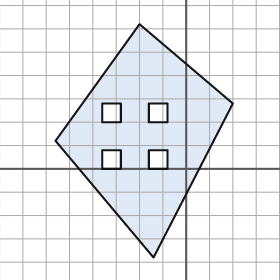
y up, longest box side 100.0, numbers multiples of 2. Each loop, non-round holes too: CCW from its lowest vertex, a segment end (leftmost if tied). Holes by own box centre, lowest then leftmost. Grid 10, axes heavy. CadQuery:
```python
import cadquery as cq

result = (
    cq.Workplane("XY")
    .moveTo(-14.0, -38.0)
    .lineTo(20.0, 28.0)
    .lineTo(-20.0, 62.0)
    .lineTo(-56.0, 12.0)
    .close()
    .moveTo(-36.0, 0.0)
    .lineTo(-28.0, 0.0)
    .lineTo(-28.0, 8.0)
    .lineTo(-36.0, 8.0)
    .close()
    .moveTo(-16.0, 0.0)
    .lineTo(-8.0, 0.0)
    .lineTo(-8.0, 8.0)
    .lineTo(-16.0, 8.0)
    .close()
    .moveTo(-36.0, 20.0)
    .lineTo(-28.0, 20.0)
    .lineTo(-28.0, 28.0)
    .lineTo(-36.0, 28.0)
    .close()
    .moveTo(-16.0, 20.0)
    .lineTo(-8.0, 20.0)
    .lineTo(-8.0, 28.0)
    .lineTo(-16.0, 28.0)
    .close()
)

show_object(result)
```